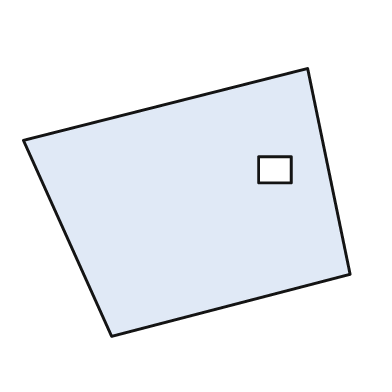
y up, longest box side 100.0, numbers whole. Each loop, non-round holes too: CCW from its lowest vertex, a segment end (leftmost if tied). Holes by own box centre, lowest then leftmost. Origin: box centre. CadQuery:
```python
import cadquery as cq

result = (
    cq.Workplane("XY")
    .moveTo(-23.0, -41.0)
    .lineTo(50.0, -22.0)
    .lineTo(37.0, 41.0)
    .lineTo(-50.0, 19.0)
    .close()
    .moveTo(22.0, 6.0)
    .lineTo(32.0, 6.0)
    .lineTo(32.0, 14.0)
    .lineTo(22.0, 14.0)
    .close()
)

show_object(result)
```